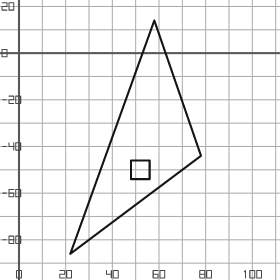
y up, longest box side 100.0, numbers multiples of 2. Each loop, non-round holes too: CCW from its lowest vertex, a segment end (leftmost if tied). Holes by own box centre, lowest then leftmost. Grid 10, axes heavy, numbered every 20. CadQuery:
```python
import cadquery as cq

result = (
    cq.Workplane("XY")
    .moveTo(22.0, -86.0)
    .lineTo(78.0, -44.0)
    .lineTo(58.0, 14.0)
    .close()
    .moveTo(48.0, -54.0)
    .lineTo(56.0, -54.0)
    .lineTo(56.0, -46.0)
    .lineTo(48.0, -46.0)
    .close()
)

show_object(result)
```